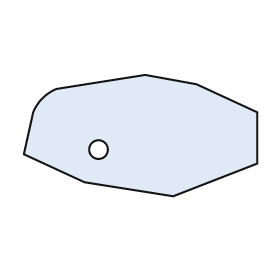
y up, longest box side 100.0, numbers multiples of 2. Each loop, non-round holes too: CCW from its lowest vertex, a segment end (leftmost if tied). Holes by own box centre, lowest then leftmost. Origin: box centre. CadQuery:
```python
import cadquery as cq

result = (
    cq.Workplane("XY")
    .moveTo(14.0, -26.0)
    .lineTo(50.0, -12.0)
    .lineTo(50.0, 10.0)
    .lineTo(24.0, 22.0)
    .lineTo(2.0, 26.0)
    .lineTo(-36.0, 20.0)
    .threePointArc((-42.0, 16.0), (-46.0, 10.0))
    .lineTo(-50.0, -8.0)
    .lineTo(-24.0, -20.0)
    .close()
    .moveTo(-18.0, -6.0)
    .circle(4.0)
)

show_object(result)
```